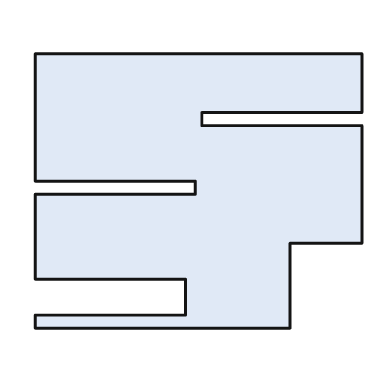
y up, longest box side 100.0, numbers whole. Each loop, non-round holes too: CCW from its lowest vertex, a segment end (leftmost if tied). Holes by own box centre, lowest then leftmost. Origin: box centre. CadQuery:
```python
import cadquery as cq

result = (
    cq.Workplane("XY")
    .moveTo(-50.0, -42.0)
    .lineTo(28.0, -42.0)
    .lineTo(28.0, -16.0)
    .lineTo(50.0, -16.0)
    .lineTo(50.0, 20.0)
    .lineTo(1.0, 20.0)
    .lineTo(1.0, 24.0)
    .lineTo(50.0, 24.0)
    .lineTo(50.0, 42.0)
    .lineTo(-50.0, 42.0)
    .lineTo(-50.0, 3.0)
    .lineTo(-1.0, 3.0)
    .lineTo(-1.0, -1.0)
    .lineTo(-50.0, -1.0)
    .lineTo(-50.0, -27.0)
    .lineTo(-4.0, -27.0)
    .lineTo(-4.0, -38.0)
    .lineTo(-50.0, -38.0)
    .close()
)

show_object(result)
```